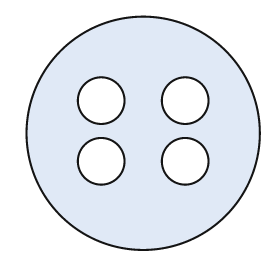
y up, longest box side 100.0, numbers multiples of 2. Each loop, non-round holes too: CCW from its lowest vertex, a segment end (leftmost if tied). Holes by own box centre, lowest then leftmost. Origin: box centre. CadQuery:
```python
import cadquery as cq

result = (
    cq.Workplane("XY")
    .moveTo(0.0, 0.0)
    .circle(50.0)
    .moveTo(-18.0, -12.0)
    .circle(10.0)
    .moveTo(18.0, -12.0)
    .circle(10.0)
    .moveTo(-18.0, 14.0)
    .circle(10.0)
    .moveTo(18.0, 14.0)
    .circle(10.0)
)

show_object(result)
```